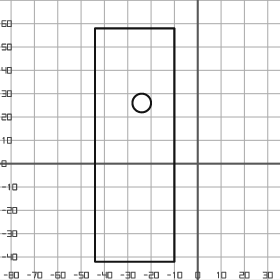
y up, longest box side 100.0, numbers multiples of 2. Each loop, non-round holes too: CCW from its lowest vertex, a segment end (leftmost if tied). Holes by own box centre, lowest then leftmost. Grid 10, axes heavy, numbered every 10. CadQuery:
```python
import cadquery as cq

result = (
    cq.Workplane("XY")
    .moveTo(-44.0, -42.0)
    .lineTo(-10.0, -42.0)
    .lineTo(-10.0, 58.0)
    .lineTo(-44.0, 58.0)
    .close()
    .moveTo(-24.0, 26.0)
    .circle(4.0)
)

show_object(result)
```